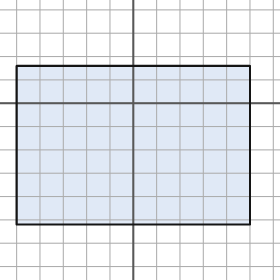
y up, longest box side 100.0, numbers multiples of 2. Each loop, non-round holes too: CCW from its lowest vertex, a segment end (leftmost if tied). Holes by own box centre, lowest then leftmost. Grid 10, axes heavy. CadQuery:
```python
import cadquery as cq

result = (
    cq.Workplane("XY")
    .moveTo(-50.0, -52.0)
    .lineTo(50.0, -52.0)
    .lineTo(50.0, 16.0)
    .lineTo(-50.0, 16.0)
    .close()
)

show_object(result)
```